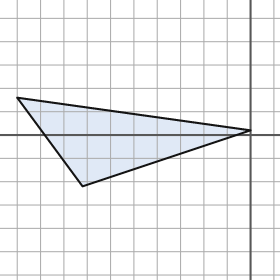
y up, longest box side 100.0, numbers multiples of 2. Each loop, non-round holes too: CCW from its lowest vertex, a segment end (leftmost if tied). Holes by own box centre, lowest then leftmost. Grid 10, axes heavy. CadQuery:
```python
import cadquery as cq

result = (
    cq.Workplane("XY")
    .moveTo(-72.0, -22.0)
    .lineTo(0.0, 2.0)
    .lineTo(-100.0, 16.0)
    .close()
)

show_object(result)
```